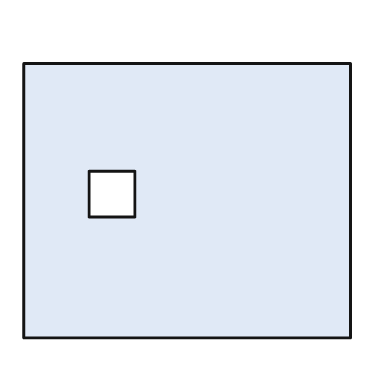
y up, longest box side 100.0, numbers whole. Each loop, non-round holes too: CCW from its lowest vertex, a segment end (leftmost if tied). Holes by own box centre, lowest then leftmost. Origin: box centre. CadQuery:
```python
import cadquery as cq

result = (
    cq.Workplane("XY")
    .moveTo(-50.0, -42.0)
    .lineTo(50.0, -42.0)
    .lineTo(50.0, 42.0)
    .lineTo(-50.0, 42.0)
    .close()
    .moveTo(-30.0, -5.0)
    .lineTo(-16.0, -5.0)
    .lineTo(-16.0, 9.0)
    .lineTo(-30.0, 9.0)
    .close()
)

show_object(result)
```